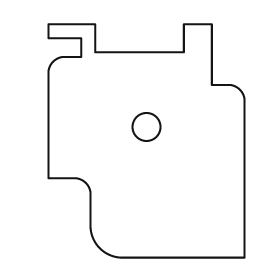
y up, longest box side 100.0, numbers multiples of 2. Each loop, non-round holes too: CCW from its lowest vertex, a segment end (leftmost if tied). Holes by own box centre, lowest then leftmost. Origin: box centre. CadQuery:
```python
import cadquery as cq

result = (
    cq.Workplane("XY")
    .moveTo(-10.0, -50.0)
    .lineTo(42.0, -50.0)
    .lineTo(42.0, 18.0)
    .threePointArc((40.0, 22.0), (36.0, 24.0))
    .lineTo(28.0, 24.0)
    .lineTo(28.0, 50.0)
    .lineTo(16.0, 50.0)
    .lineTo(16.0, 38.0)
    .lineTo(-22.0, 38.0)
    .lineTo(-22.0, 50.0)
    .lineTo(-42.0, 50.0)
    .lineTo(-42.0, 44.0)
    .lineTo(-28.0, 44.0)
    .lineTo(-28.0, 36.0)
    .lineTo(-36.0, 36.0)
    .threePointArc((-40.0, 34.0), (-42.0, 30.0))
    .lineTo(-42.0, -16.0)
    .lineTo(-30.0, -16.0)
    .threePointArc((-26.0, -18.0), (-24.0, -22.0))
    .lineTo(-24.0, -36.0)
    .threePointArc((-20.0, -46.0), (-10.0, -50.0))
    .close()
    .moveTo(0.0, 6.0)
    .circle(6.0)
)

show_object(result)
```